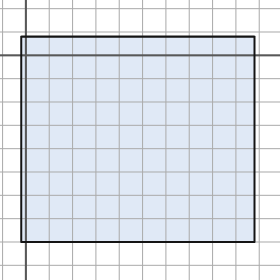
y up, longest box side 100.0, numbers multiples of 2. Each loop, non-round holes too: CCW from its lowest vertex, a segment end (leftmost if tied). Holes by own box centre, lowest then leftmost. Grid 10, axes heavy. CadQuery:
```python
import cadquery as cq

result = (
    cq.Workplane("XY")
    .moveTo(-2.0, -80.0)
    .lineTo(98.0, -80.0)
    .lineTo(98.0, 8.0)
    .lineTo(-2.0, 8.0)
    .close()
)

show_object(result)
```